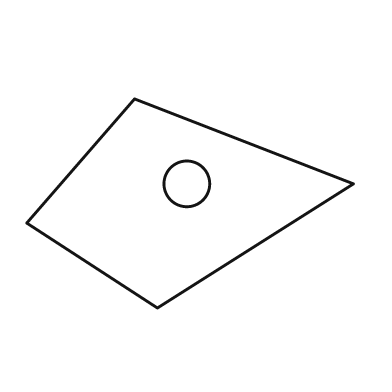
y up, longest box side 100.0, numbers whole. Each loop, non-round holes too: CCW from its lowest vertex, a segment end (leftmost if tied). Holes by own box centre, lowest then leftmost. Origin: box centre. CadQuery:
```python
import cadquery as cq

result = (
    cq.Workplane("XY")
    .moveTo(-10.0, -32.0)
    .lineTo(50.0, 6.0)
    .lineTo(-17.0, 32.0)
    .lineTo(-50.0, -6.0)
    .close()
    .moveTo(-1.0, 6.0)
    .circle(7.0)
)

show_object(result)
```